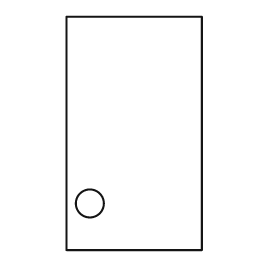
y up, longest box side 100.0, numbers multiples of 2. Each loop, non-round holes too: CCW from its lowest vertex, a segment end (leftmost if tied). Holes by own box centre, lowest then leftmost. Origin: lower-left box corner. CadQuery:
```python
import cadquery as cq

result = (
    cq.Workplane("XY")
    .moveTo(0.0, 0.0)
    .lineTo(58.0, 0.0)
    .lineTo(58.0, 100.0)
    .lineTo(0.0, 100.0)
    .close()
    .moveTo(10.0, 20.0)
    .circle(6.0)
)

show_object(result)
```